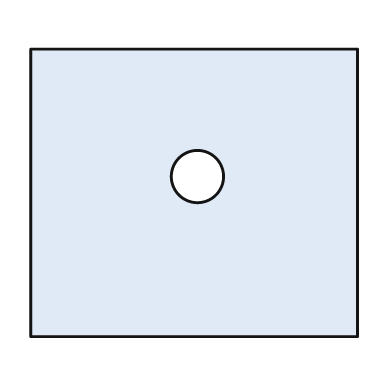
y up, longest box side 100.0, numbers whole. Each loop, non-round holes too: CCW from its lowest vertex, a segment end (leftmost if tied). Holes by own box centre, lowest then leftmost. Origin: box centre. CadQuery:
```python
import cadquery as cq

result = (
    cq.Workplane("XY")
    .moveTo(-50.0, -44.0)
    .lineTo(50.0, -44.0)
    .lineTo(50.0, 44.0)
    .lineTo(-50.0, 44.0)
    .close()
    .moveTo(1.0, 5.0)
    .circle(8.0)
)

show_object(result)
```